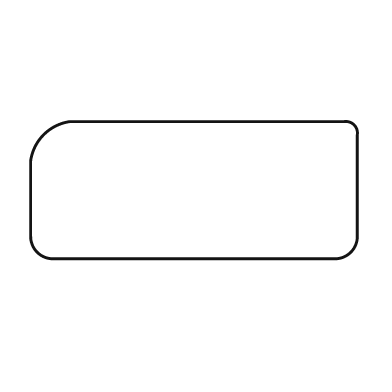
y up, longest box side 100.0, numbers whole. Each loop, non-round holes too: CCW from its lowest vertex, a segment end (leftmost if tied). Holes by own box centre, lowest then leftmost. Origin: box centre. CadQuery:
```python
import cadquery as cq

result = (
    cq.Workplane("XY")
    .moveTo(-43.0, -21.0)
    .lineTo(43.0, -21.0)
    .threePointArc((48.0, -19.0), (50.0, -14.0))
    .lineTo(50.0, 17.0)
    .threePointArc((49.0, 20.0), (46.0, 21.0))
    .lineTo(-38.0, 21.0)
    .threePointArc((-46.0, 17.0), (-50.0, 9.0))
    .lineTo(-50.0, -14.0)
    .threePointArc((-48.0, -19.0), (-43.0, -21.0))
    .close()
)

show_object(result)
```